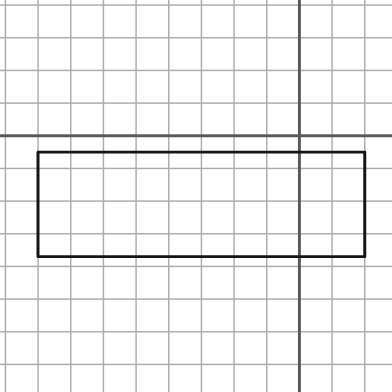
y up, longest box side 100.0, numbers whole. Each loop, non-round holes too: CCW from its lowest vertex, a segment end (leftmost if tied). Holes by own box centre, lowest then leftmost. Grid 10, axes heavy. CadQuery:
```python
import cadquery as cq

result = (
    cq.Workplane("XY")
    .moveTo(-80.0, -37.0)
    .lineTo(20.0, -37.0)
    .lineTo(20.0, -5.0)
    .lineTo(-80.0, -5.0)
    .close()
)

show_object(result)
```